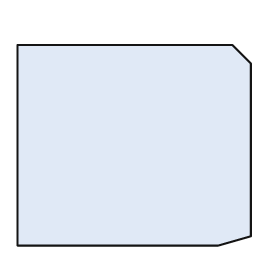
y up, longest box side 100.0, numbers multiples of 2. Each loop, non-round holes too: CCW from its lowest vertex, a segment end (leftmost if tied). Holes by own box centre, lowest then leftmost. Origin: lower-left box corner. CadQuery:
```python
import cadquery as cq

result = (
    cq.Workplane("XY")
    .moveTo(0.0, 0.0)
    .lineTo(86.0, 0.0)
    .lineTo(100.0, 4.0)
    .lineTo(100.0, 78.0)
    .lineTo(92.0, 86.0)
    .lineTo(0.0, 86.0)
    .close()
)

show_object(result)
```